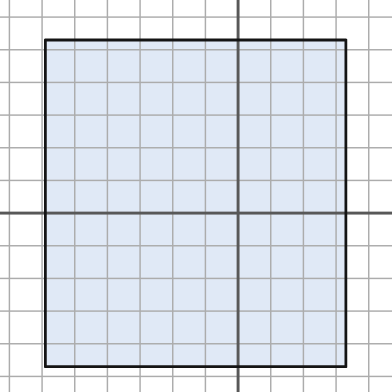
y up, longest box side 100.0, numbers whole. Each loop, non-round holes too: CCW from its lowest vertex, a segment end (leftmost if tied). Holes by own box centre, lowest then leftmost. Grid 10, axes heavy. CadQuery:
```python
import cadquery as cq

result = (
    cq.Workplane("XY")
    .moveTo(-59.0, -47.0)
    .lineTo(33.0, -47.0)
    .lineTo(33.0, 53.0)
    .lineTo(-59.0, 53.0)
    .close()
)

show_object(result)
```